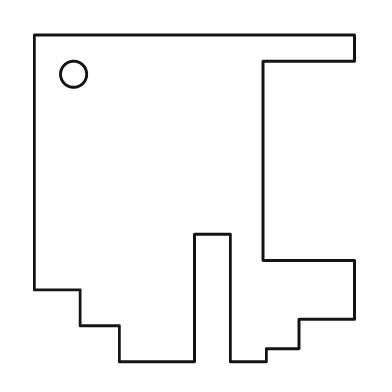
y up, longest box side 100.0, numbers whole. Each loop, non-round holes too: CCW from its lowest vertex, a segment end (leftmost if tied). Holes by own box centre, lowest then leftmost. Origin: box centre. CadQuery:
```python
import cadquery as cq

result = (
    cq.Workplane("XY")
    .moveTo(-23.0, -50.0)
    .lineTo(0.0, -50.0)
    .lineTo(0.0, -11.0)
    .lineTo(11.0, -11.0)
    .lineTo(11.0, -50.0)
    .lineTo(22.0, -50.0)
    .lineTo(22.0, -46.0)
    .lineTo(32.0, -46.0)
    .lineTo(32.0, -37.0)
    .lineTo(49.0, -37.0)
    .lineTo(49.0, -19.0)
    .lineTo(21.0, -19.0)
    .lineTo(21.0, 42.0)
    .lineTo(49.0, 42.0)
    .lineTo(49.0, 50.0)
    .lineTo(-49.0, 50.0)
    .lineTo(-49.0, -28.0)
    .lineTo(-35.0, -28.0)
    .lineTo(-35.0, -39.0)
    .lineTo(-23.0, -39.0)
    .close()
    .moveTo(-37.0, 38.0)
    .circle(4.0)
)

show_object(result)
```